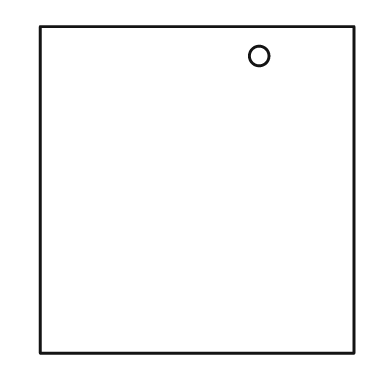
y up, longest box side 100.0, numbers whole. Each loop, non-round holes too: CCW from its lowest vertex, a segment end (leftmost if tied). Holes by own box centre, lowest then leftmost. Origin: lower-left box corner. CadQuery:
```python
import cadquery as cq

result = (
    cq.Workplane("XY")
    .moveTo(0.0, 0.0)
    .lineTo(96.0, 0.0)
    .lineTo(96.0, 100.0)
    .lineTo(0.0, 100.0)
    .close()
    .moveTo(67.0, 91.0)
    .circle(3.0)
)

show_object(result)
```